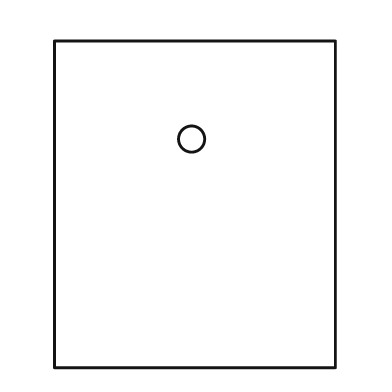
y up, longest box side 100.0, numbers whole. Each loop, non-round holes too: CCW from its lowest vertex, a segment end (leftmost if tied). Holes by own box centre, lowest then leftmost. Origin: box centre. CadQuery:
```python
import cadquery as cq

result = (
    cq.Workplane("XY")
    .moveTo(-43.0, -50.0)
    .lineTo(43.0, -50.0)
    .lineTo(43.0, 50.0)
    .lineTo(-43.0, 50.0)
    .close()
    .moveTo(-1.0, 20.0)
    .circle(4.0)
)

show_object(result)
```